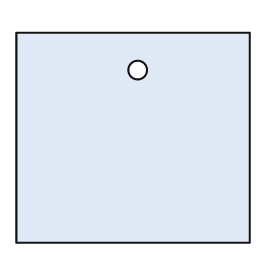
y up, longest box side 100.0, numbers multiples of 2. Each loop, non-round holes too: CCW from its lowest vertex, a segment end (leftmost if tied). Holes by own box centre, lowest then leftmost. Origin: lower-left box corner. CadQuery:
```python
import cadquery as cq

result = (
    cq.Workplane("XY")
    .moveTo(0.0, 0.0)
    .lineTo(100.0, 0.0)
    .lineTo(100.0, 90.0)
    .lineTo(0.0, 90.0)
    .close()
    .moveTo(52.0, 74.0)
    .circle(4.0)
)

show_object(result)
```